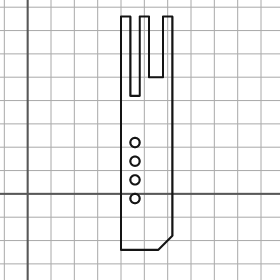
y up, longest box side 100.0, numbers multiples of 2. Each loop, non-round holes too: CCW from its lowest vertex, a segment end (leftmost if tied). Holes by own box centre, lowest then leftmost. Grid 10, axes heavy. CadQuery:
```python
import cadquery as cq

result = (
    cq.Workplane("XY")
    .moveTo(40.0, -24.0)
    .lineTo(56.0, -24.0)
    .lineTo(62.0, -18.0)
    .lineTo(62.0, 76.0)
    .lineTo(58.0, 76.0)
    .lineTo(58.0, 50.0)
    .lineTo(52.0, 50.0)
    .lineTo(52.0, 76.0)
    .lineTo(48.0, 76.0)
    .lineTo(48.0, 42.0)
    .lineTo(44.0, 42.0)
    .lineTo(44.0, 76.0)
    .lineTo(40.0, 76.0)
    .close()
    .moveTo(46.0, -2.0)
    .circle(2.0)
    .moveTo(46.0, 6.0)
    .circle(2.0)
    .moveTo(46.0, 14.0)
    .circle(2.0)
    .moveTo(46.0, 22.0)
    .circle(2.0)
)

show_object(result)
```